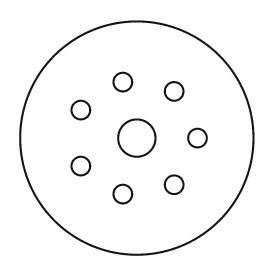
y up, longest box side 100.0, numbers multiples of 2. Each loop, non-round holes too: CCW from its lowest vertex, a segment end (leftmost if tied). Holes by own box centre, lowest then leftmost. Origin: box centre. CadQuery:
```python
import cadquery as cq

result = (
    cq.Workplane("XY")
    .moveTo(0.0, 0.0)
    .circle(50.0)
    .moveTo(-6.0, -24.0)
    .circle(4.0)
    .moveTo(16.0, -20.0)
    .circle(4.0)
    .moveTo(-24.0, -12.0)
    .circle(4.0)
    .moveTo(0.0, 0.0)
    .circle(8.0)
    .moveTo(26.0, 0.0)
    .circle(4.0)
    .moveTo(-24.0, 12.0)
    .circle(4.0)
    .moveTo(16.0, 20.0)
    .circle(4.0)
    .moveTo(-6.0, 24.0)
    .circle(4.0)
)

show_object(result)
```